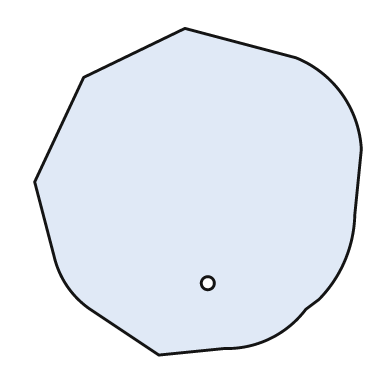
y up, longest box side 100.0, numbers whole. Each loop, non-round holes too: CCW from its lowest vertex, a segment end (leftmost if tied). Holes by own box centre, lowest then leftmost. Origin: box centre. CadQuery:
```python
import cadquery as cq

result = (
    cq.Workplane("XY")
    .moveTo(-12.0, -50.0)
    .lineTo(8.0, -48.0)
    .threePointArc((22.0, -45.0), (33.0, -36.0))
    .lineTo(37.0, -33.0)
    .threePointArc((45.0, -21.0), (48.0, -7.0))
    .lineTo(50.0, 13.0)
    .threePointArc((44.0, 30.0), (30.0, 41.0))
    .lineTo(-4.0, 50.0)
    .lineTo(-35.0, 35.0)
    .lineTo(-50.0, 3.0)
    .lineTo(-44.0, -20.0)
    .threePointArc((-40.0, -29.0), (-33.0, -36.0))
    .close()
    .moveTo(3.0, -28.0)
    .circle(2.0)
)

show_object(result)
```